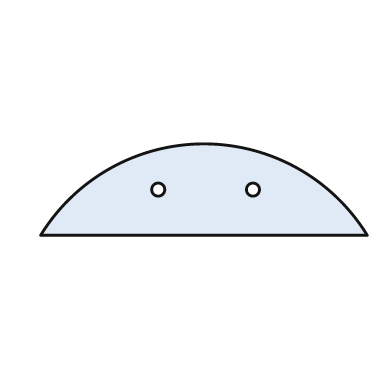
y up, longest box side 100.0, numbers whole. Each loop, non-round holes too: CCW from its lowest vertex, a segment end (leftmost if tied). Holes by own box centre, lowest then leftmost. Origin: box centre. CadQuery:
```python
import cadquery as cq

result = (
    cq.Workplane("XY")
    .moveTo(-50.0, -14.0)
    .lineTo(50.0, -14.0)
    .threePointArc((0.0, 14.0), (-50.0, -14.0))
    .close()
    .moveTo(-14.0, 0.0)
    .circle(2.0)
    .moveTo(15.0, 0.0)
    .circle(2.0)
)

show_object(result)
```